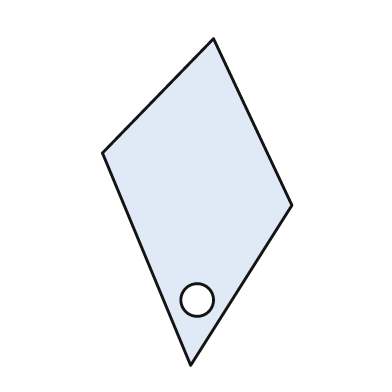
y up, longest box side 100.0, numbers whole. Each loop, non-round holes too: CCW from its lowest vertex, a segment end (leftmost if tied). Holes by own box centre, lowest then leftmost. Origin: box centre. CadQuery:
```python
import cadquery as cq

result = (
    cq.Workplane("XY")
    .moveTo(-2.0, -50.0)
    .lineTo(29.0, -1.0)
    .lineTo(5.0, 50.0)
    .lineTo(-29.0, 15.0)
    .close()
    .moveTo(0.0, -30.0)
    .circle(5.0)
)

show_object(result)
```